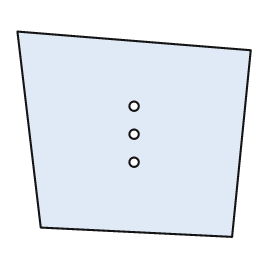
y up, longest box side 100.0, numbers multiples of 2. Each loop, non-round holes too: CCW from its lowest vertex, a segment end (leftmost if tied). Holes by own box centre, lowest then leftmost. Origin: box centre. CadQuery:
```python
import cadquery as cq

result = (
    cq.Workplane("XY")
    .moveTo(42.0, -44.0)
    .lineTo(50.0, 36.0)
    .lineTo(-50.0, 44.0)
    .lineTo(-40.0, -40.0)
    .close()
    .moveTo(0.0, -12.0)
    .circle(2.0)
    .moveTo(0.0, 0.0)
    .circle(2.0)
    .moveTo(0.0, 12.0)
    .circle(2.0)
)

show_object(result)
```